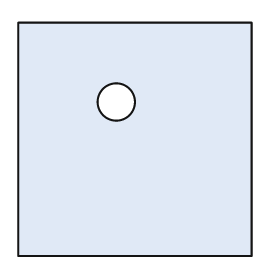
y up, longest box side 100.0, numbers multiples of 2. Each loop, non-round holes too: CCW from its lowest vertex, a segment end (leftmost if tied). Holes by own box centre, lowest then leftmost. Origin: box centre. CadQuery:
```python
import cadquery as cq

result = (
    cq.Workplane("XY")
    .moveTo(-50.0, -50.0)
    .lineTo(50.0, -50.0)
    .lineTo(50.0, 50.0)
    .lineTo(-50.0, 50.0)
    .close()
    .moveTo(-8.0, 16.0)
    .circle(8.0)
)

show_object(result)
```